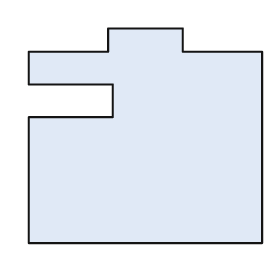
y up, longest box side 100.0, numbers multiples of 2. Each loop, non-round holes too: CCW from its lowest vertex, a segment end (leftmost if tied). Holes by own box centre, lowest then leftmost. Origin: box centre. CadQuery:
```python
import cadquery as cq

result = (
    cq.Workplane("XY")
    .moveTo(-50.0, -46.0)
    .lineTo(50.0, -46.0)
    .lineTo(50.0, 36.0)
    .lineTo(16.0, 36.0)
    .lineTo(16.0, 46.0)
    .lineTo(-16.0, 46.0)
    .lineTo(-16.0, 36.0)
    .lineTo(-50.0, 36.0)
    .lineTo(-50.0, 22.0)
    .lineTo(-14.0, 22.0)
    .lineTo(-14.0, 8.0)
    .lineTo(-50.0, 8.0)
    .close()
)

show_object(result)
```